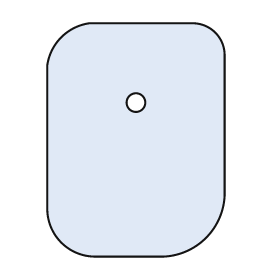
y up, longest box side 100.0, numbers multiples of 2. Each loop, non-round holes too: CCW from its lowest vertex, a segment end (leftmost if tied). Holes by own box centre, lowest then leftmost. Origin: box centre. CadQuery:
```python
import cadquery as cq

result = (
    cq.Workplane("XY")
    .moveTo(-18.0, -50.0)
    .lineTo(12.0, -50.0)
    .threePointArc((30.0, -42.0), (38.0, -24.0))
    .lineTo(38.0, 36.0)
    .threePointArc((34.0, 46.0), (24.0, 50.0))
    .lineTo(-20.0, 50.0)
    .threePointArc((-32.0, 44.0), (-38.0, 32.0))
    .lineTo(-38.0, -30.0)
    .threePointArc((-32.0, -44.0), (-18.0, -50.0))
    .close()
    .moveTo(0.0, 16.0)
    .circle(4.0)
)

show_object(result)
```